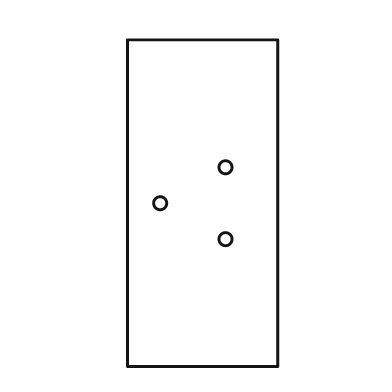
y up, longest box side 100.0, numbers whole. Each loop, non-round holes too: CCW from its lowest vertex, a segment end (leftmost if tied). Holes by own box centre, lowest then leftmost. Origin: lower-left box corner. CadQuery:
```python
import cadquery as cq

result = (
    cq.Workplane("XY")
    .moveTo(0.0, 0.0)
    .lineTo(46.0, 0.0)
    .lineTo(46.0, 100.0)
    .lineTo(0.0, 100.0)
    .close()
    .moveTo(30.0, 39.0)
    .circle(2.0)
    .moveTo(10.0, 50.0)
    .circle(2.0)
    .moveTo(30.0, 61.0)
    .circle(2.0)
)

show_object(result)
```